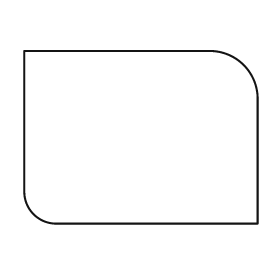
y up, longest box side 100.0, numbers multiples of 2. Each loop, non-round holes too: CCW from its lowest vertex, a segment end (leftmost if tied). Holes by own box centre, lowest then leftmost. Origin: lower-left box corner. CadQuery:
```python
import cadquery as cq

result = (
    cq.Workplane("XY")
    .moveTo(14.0, 0.0)
    .lineTo(100.0, 0.0)
    .lineTo(100.0, 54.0)
    .threePointArc((94.0, 68.0), (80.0, 74.0))
    .lineTo(0.0, 74.0)
    .lineTo(0.0, 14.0)
    .threePointArc((4.0, 4.0), (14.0, 0.0))
    .close()
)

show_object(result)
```